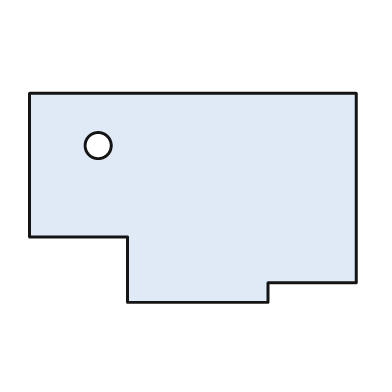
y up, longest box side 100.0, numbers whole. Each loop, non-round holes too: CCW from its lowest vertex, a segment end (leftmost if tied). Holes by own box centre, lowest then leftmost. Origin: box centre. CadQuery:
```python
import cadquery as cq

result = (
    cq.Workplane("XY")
    .moveTo(-20.0, -32.0)
    .lineTo(23.0, -32.0)
    .lineTo(23.0, -26.0)
    .lineTo(50.0, -26.0)
    .lineTo(50.0, 32.0)
    .lineTo(-50.0, 32.0)
    .lineTo(-50.0, -12.0)
    .lineTo(-20.0, -12.0)
    .close()
    .moveTo(-29.0, 16.0)
    .circle(4.0)
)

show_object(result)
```